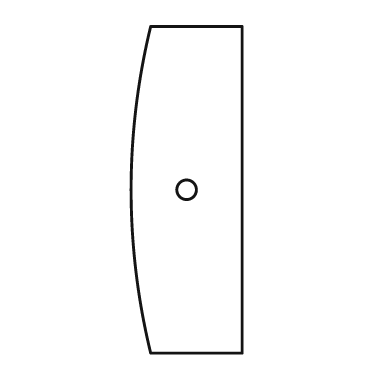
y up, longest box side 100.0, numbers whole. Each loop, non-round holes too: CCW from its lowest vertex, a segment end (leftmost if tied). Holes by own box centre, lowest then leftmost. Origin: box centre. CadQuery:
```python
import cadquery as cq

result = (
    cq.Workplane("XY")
    .moveTo(-11.0, -50.0)
    .lineTo(17.0, -50.0)
    .lineTo(17.0, 50.0)
    .lineTo(-11.0, 50.0)
    .threePointArc((-17.0, 0.0), (-11.0, -50.0))
    .close()
    .moveTo(0.0, 0.0)
    .circle(3.0)
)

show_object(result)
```